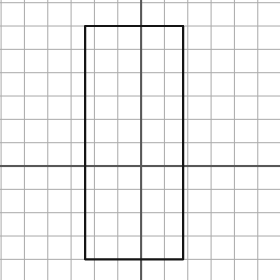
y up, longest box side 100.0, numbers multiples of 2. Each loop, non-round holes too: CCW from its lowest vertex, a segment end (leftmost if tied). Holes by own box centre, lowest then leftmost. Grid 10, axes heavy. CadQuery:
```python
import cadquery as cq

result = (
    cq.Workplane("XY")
    .moveTo(-24.0, -40.0)
    .lineTo(18.0, -40.0)
    .lineTo(18.0, 60.0)
    .lineTo(-24.0, 60.0)
    .close()
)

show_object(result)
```